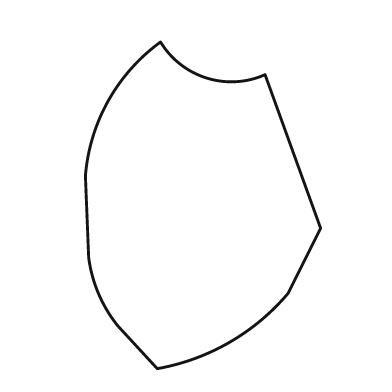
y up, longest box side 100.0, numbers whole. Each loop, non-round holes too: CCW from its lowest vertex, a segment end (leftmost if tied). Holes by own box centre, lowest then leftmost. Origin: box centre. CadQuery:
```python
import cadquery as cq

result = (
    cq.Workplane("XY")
    .moveTo(-14.0, -50.0)
    .threePointArc((8.0, -42.0), (26.0, -27.0))
    .lineTo(36.0, -7.0)
    .lineTo(19.0, 40.0)
    .threePointArc((1.0, 39.0), (-13.0, 50.0))
    .threePointArc((-29.0, 32.0), (-36.0, 9.0))
    .lineTo(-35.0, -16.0)
    .threePointArc((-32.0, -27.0), (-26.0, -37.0))
    .close()
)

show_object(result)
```